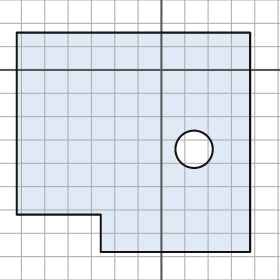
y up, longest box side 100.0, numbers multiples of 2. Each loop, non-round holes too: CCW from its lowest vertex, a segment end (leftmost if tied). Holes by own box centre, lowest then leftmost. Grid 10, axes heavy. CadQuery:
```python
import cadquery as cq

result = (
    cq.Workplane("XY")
    .moveTo(-26.0, -78.0)
    .lineTo(38.0, -78.0)
    .lineTo(38.0, 16.0)
    .lineTo(-62.0, 16.0)
    .lineTo(-62.0, -62.0)
    .lineTo(-26.0, -62.0)
    .close()
    .moveTo(14.0, -34.0)
    .circle(8.0)
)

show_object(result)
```